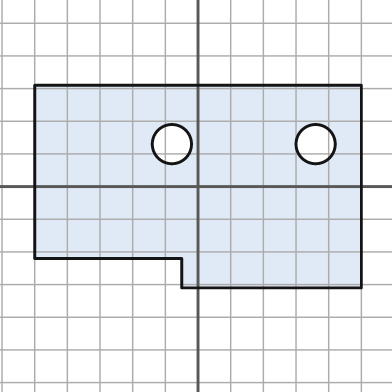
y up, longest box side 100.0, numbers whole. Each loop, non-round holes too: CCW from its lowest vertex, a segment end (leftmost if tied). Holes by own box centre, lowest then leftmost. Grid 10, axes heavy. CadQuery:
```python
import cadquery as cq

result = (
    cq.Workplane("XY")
    .moveTo(-5.0, -31.0)
    .lineTo(50.0, -31.0)
    .lineTo(50.0, 31.0)
    .lineTo(-50.0, 31.0)
    .lineTo(-50.0, -22.0)
    .lineTo(-5.0, -22.0)
    .close()
    .moveTo(-8.0, 13.0)
    .circle(6.0)
    .moveTo(36.0, 13.0)
    .circle(6.0)
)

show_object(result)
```